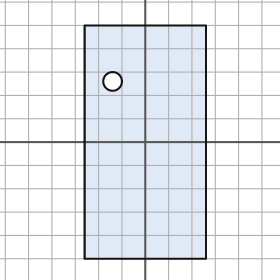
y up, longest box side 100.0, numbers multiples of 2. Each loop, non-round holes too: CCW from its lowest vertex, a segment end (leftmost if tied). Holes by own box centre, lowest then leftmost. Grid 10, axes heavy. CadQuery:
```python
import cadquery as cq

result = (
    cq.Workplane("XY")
    .moveTo(-26.0, -50.0)
    .lineTo(26.0, -50.0)
    .lineTo(26.0, 50.0)
    .lineTo(-26.0, 50.0)
    .close()
    .moveTo(-14.0, 26.0)
    .circle(4.0)
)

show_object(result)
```